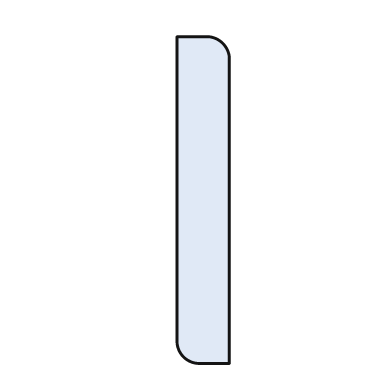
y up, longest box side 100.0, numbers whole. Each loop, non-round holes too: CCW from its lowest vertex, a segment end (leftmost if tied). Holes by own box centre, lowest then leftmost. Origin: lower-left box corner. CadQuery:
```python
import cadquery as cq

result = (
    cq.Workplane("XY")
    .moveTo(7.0, 0.0)
    .lineTo(16.0, 0.0)
    .lineTo(16.0, 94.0)
    .threePointArc((14.0, 98.0), (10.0, 100.0))
    .lineTo(0.0, 100.0)
    .lineTo(0.0, 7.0)
    .threePointArc((2.0, 2.0), (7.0, 0.0))
    .close()
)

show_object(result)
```